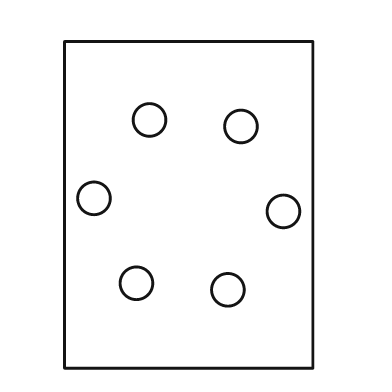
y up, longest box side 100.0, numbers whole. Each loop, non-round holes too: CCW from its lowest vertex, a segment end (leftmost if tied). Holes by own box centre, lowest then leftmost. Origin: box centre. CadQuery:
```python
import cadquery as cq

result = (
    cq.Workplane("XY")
    .moveTo(-38.0, -50.0)
    .lineTo(38.0, -50.0)
    .lineTo(38.0, 50.0)
    .lineTo(-38.0, 50.0)
    .close()
    .moveTo(12.0, -26.0)
    .circle(5.0)
    .moveTo(-16.0, -24.0)
    .circle(5.0)
    .moveTo(29.0, -2.0)
    .circle(5.0)
    .moveTo(-29.0, 2.0)
    .circle(5.0)
    .moveTo(16.0, 24.0)
    .circle(5.0)
    .moveTo(-12.0, 26.0)
    .circle(5.0)
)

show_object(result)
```